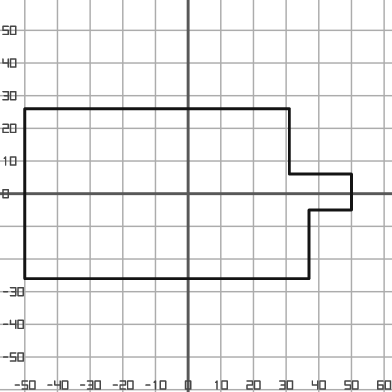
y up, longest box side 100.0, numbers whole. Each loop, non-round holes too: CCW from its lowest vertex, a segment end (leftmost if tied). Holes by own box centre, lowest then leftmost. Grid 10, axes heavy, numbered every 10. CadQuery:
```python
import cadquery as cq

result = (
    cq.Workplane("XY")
    .moveTo(-50.0, -26.0)
    .lineTo(37.0, -26.0)
    .lineTo(37.0, -5.0)
    .lineTo(50.0, -5.0)
    .lineTo(50.0, 6.0)
    .lineTo(31.0, 6.0)
    .lineTo(31.0, 26.0)
    .lineTo(-50.0, 26.0)
    .close()
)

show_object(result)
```